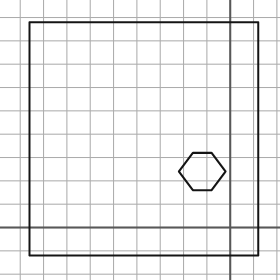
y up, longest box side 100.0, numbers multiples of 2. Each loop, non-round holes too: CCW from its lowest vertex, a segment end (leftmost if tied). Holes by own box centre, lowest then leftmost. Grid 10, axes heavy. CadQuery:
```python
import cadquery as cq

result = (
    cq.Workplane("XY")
    .moveTo(-86.0, -12.0)
    .lineTo(12.0, -12.0)
    .lineTo(12.0, 88.0)
    .lineTo(-86.0, 88.0)
    .close()
    .moveTo(-16.0, 16.0)
    .lineTo(-8.0, 16.0)
    .lineTo(-2.0, 24.0)
    .lineTo(-8.0, 32.0)
    .lineTo(-16.0, 32.0)
    .lineTo(-22.0, 24.0)
    .close()
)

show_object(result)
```